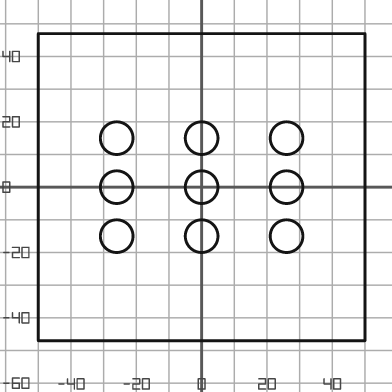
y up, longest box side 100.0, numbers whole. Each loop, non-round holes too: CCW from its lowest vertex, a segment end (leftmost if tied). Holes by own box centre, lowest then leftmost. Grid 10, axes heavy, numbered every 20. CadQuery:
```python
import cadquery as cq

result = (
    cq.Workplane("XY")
    .moveTo(-50.0, -47.0)
    .lineTo(50.0, -47.0)
    .lineTo(50.0, 47.0)
    .lineTo(-50.0, 47.0)
    .close()
    .moveTo(-26.0, -15.0)
    .circle(5.0)
    .moveTo(0.0, -15.0)
    .circle(5.0)
    .moveTo(26.0, -15.0)
    .circle(5.0)
    .moveTo(-26.0, 0.0)
    .circle(5.0)
    .moveTo(0.0, 0.0)
    .circle(5.0)
    .moveTo(26.0, 0.0)
    .circle(5.0)
    .moveTo(-26.0, 15.0)
    .circle(5.0)
    .moveTo(0.0, 15.0)
    .circle(5.0)
    .moveTo(26.0, 15.0)
    .circle(5.0)
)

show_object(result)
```